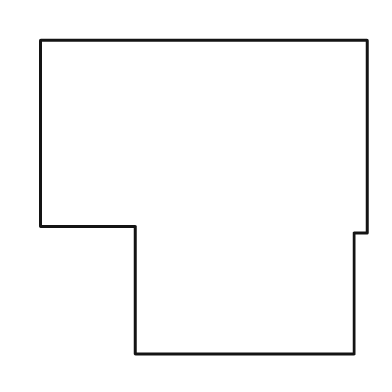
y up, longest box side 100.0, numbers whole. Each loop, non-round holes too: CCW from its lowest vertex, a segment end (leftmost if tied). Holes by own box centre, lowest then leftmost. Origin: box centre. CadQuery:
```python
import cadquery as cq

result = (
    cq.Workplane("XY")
    .moveTo(-21.0, -48.0)
    .lineTo(46.0, -48.0)
    .lineTo(46.0, -11.0)
    .lineTo(50.0, -11.0)
    .lineTo(50.0, 48.0)
    .lineTo(-50.0, 48.0)
    .lineTo(-50.0, -9.0)
    .lineTo(-21.0, -9.0)
    .close()
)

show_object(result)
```